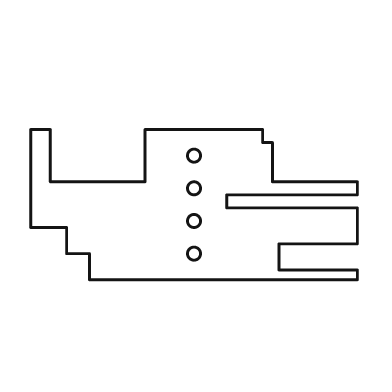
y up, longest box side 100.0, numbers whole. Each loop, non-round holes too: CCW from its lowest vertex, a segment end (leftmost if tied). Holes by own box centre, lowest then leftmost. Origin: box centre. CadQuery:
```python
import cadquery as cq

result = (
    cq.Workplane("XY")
    .moveTo(-32.0, -23.0)
    .lineTo(50.0, -23.0)
    .lineTo(50.0, -20.0)
    .lineTo(26.0, -20.0)
    .lineTo(26.0, -12.0)
    .lineTo(50.0, -12.0)
    .lineTo(50.0, -1.0)
    .lineTo(10.0, -1.0)
    .lineTo(10.0, 3.0)
    .lineTo(50.0, 3.0)
    .lineTo(50.0, 7.0)
    .lineTo(24.0, 7.0)
    .lineTo(24.0, 19.0)
    .lineTo(21.0, 19.0)
    .lineTo(21.0, 23.0)
    .lineTo(-15.0, 23.0)
    .lineTo(-15.0, 7.0)
    .lineTo(-44.0, 7.0)
    .lineTo(-44.0, 23.0)
    .lineTo(-50.0, 23.0)
    .lineTo(-50.0, -7.0)
    .lineTo(-39.0, -7.0)
    .lineTo(-39.0, -15.0)
    .lineTo(-32.0, -15.0)
    .close()
    .moveTo(0.0, -15.0)
    .circle(2.0)
    .moveTo(0.0, -5.0)
    .circle(2.0)
    .moveTo(0.0, 5.0)
    .circle(2.0)
    .moveTo(0.0, 15.0)
    .circle(2.0)
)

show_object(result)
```